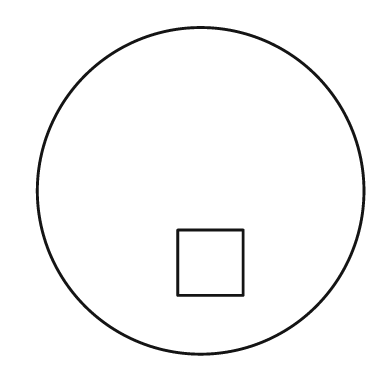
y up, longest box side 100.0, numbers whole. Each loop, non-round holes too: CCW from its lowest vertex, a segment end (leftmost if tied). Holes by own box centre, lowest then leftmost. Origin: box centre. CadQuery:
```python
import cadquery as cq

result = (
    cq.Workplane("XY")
    .moveTo(0.0, 0.0)
    .circle(50.0)
    .moveTo(-7.0, -32.0)
    .lineTo(13.0, -32.0)
    .lineTo(13.0, -12.0)
    .lineTo(-7.0, -12.0)
    .close()
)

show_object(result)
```